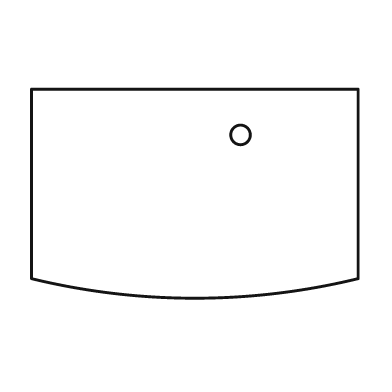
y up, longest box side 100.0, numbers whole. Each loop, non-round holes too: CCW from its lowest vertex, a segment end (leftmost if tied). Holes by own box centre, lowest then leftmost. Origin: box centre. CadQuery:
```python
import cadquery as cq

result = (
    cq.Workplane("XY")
    .moveTo(-50.0, -26.0)
    .threePointArc((0.0, -32.0), (50.0, -26.0))
    .lineTo(50.0, 32.0)
    .lineTo(-50.0, 32.0)
    .close()
    .moveTo(14.0, 18.0)
    .circle(3.0)
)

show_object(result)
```